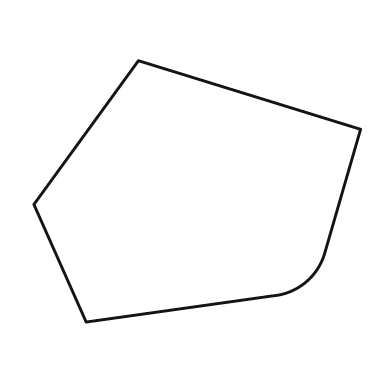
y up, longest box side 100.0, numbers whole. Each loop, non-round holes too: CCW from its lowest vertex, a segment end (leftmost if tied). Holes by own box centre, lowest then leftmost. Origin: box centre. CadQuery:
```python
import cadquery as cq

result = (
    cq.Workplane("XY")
    .moveTo(-34.0, -40.0)
    .lineTo(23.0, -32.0)
    .threePointArc((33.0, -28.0), (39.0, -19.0))
    .lineTo(50.0, 19.0)
    .lineTo(-18.0, 40.0)
    .lineTo(-50.0, -4.0)
    .close()
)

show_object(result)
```